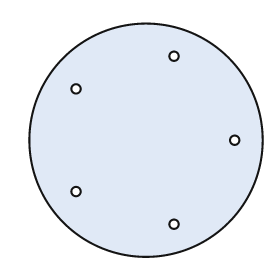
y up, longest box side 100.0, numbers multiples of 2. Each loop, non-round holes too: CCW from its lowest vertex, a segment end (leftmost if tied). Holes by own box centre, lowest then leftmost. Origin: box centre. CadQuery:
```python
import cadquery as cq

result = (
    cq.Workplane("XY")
    .moveTo(0.0, 0.0)
    .circle(50.0)
    .moveTo(12.0, -36.0)
    .circle(2.0)
    .moveTo(-30.0, -22.0)
    .circle(2.0)
    .moveTo(38.0, 0.0)
    .circle(2.0)
    .moveTo(-30.0, 22.0)
    .circle(2.0)
    .moveTo(12.0, 36.0)
    .circle(2.0)
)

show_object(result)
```